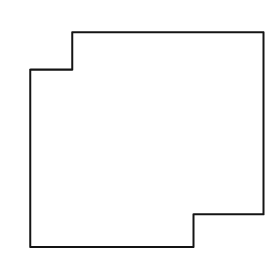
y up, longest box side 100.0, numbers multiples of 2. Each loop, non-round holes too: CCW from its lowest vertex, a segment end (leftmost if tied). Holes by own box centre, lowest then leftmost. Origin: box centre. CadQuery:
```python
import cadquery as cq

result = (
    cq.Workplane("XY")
    .moveTo(-50.0, -46.0)
    .lineTo(20.0, -46.0)
    .lineTo(20.0, -32.0)
    .lineTo(50.0, -32.0)
    .lineTo(50.0, 46.0)
    .lineTo(-32.0, 46.0)
    .lineTo(-32.0, 30.0)
    .lineTo(-50.0, 30.0)
    .close()
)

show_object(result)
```